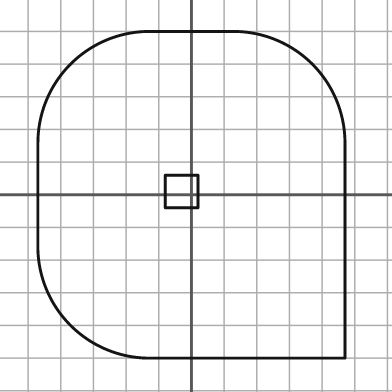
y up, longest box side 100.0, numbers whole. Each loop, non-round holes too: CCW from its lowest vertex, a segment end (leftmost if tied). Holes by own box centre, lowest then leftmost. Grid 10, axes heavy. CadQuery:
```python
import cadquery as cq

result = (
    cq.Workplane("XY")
    .moveTo(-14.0, -50.0)
    .lineTo(47.0, -50.0)
    .lineTo(47.0, 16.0)
    .threePointArc((37.0, 40.0), (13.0, 50.0))
    .lineTo(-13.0, 50.0)
    .threePointArc((-37.0, 40.0), (-47.0, 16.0))
    .lineTo(-47.0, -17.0)
    .threePointArc((-37.0, -40.0), (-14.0, -50.0))
    .close()
    .moveTo(-8.0, -4.0)
    .lineTo(2.0, -4.0)
    .lineTo(2.0, 6.0)
    .lineTo(-8.0, 6.0)
    .close()
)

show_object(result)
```